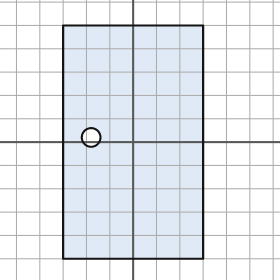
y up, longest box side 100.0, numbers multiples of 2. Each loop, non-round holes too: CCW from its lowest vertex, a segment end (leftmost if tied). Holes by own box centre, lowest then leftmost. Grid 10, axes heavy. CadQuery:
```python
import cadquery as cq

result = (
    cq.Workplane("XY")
    .moveTo(-30.0, -50.0)
    .lineTo(30.0, -50.0)
    .lineTo(30.0, 50.0)
    .lineTo(-30.0, 50.0)
    .close()
    .moveTo(-18.0, 2.0)
    .circle(4.0)
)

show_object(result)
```